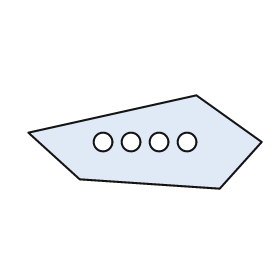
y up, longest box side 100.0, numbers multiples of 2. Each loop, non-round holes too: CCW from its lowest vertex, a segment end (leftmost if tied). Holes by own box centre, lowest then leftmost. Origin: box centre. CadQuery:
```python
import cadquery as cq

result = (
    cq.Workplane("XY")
    .moveTo(32.0, -20.0)
    .lineTo(50.0, 0.0)
    .lineTo(22.0, 20.0)
    .lineTo(-50.0, 4.0)
    .lineTo(-28.0, -16.0)
    .close()
    .moveTo(-18.0, 0.0)
    .circle(4.0)
    .moveTo(-6.0, 0.0)
    .circle(4.0)
    .moveTo(6.0, 0.0)
    .circle(4.0)
    .moveTo(18.0, 0.0)
    .circle(4.0)
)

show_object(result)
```